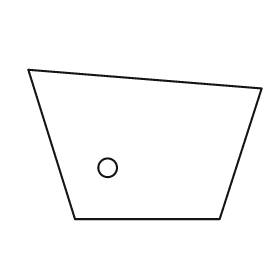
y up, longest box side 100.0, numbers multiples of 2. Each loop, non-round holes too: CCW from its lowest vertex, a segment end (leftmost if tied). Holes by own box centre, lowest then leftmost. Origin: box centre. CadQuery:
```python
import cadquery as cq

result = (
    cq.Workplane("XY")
    .moveTo(-30.0, -32.0)
    .lineTo(32.0, -32.0)
    .lineTo(50.0, 24.0)
    .lineTo(-50.0, 32.0)
    .close()
    .moveTo(-16.0, -10.0)
    .circle(4.0)
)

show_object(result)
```